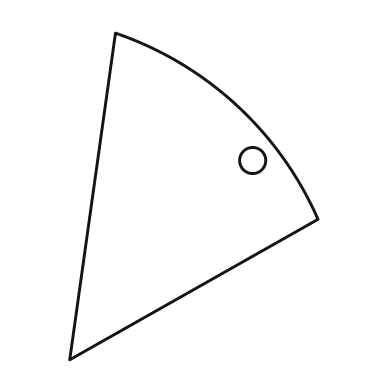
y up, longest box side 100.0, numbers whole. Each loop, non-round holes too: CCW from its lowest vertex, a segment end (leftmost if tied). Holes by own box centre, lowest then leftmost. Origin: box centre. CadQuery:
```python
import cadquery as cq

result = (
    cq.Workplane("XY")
    .moveTo(-38.0, -50.0)
    .lineTo(38.0, -7.0)
    .threePointArc((13.0, 28.0), (-24.0, 50.0))
    .close()
    .moveTo(18.0, 11.0)
    .circle(4.0)
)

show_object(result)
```